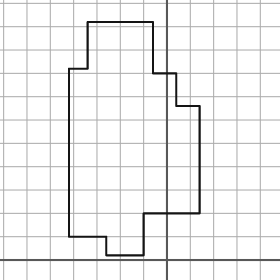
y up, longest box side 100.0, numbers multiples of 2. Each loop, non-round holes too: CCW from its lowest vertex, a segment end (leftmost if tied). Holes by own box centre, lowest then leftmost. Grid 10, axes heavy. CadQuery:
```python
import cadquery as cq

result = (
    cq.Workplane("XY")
    .moveTo(-26.0, 2.0)
    .lineTo(-10.0, 2.0)
    .lineTo(-10.0, 20.0)
    .lineTo(14.0, 20.0)
    .lineTo(14.0, 66.0)
    .lineTo(4.0, 66.0)
    .lineTo(4.0, 80.0)
    .lineTo(-6.0, 80.0)
    .lineTo(-6.0, 102.0)
    .lineTo(-34.0, 102.0)
    .lineTo(-34.0, 82.0)
    .lineTo(-42.0, 82.0)
    .lineTo(-42.0, 10.0)
    .lineTo(-26.0, 10.0)
    .close()
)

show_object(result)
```